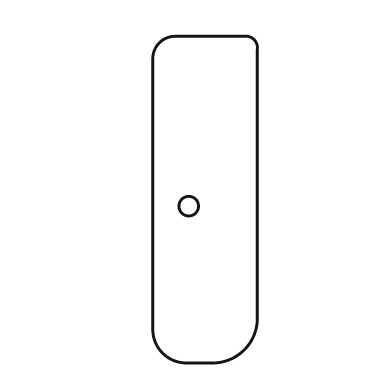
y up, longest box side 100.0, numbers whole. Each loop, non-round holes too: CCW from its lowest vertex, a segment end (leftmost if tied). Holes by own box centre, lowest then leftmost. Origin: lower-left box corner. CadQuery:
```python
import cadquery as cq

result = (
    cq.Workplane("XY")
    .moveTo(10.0, 0.0)
    .lineTo(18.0, 0.0)
    .threePointArc((28.0, 4.0), (32.0, 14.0))
    .lineTo(32.0, 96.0)
    .threePointArc((31.0, 99.0), (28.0, 100.0))
    .lineTo(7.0, 100.0)
    .threePointArc((2.0, 98.0), (0.0, 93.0))
    .lineTo(0.0, 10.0)
    .threePointArc((3.0, 3.0), (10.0, 0.0))
    .close()
    .moveTo(11.0, 48.0)
    .circle(3.0)
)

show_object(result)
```